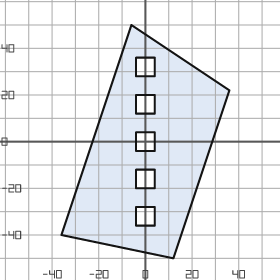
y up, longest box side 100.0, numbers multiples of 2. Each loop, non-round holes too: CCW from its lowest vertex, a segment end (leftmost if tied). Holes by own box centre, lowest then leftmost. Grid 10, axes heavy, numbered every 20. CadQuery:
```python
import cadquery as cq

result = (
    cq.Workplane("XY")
    .moveTo(12.0, -50.0)
    .lineTo(36.0, 22.0)
    .lineTo(-6.0, 50.0)
    .lineTo(-36.0, -40.0)
    .close()
    .moveTo(-4.0, -36.0)
    .lineTo(4.0, -36.0)
    .lineTo(4.0, -28.0)
    .lineTo(-4.0, -28.0)
    .close()
    .moveTo(-4.0, -20.0)
    .lineTo(4.0, -20.0)
    .lineTo(4.0, -12.0)
    .lineTo(-4.0, -12.0)
    .close()
    .moveTo(-4.0, -4.0)
    .lineTo(4.0, -4.0)
    .lineTo(4.0, 4.0)
    .lineTo(-4.0, 4.0)
    .close()
    .moveTo(-4.0, 12.0)
    .lineTo(4.0, 12.0)
    .lineTo(4.0, 20.0)
    .lineTo(-4.0, 20.0)
    .close()
    .moveTo(-4.0, 28.0)
    .lineTo(4.0, 28.0)
    .lineTo(4.0, 36.0)
    .lineTo(-4.0, 36.0)
    .close()
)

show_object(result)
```